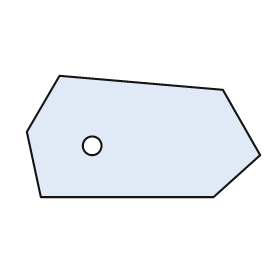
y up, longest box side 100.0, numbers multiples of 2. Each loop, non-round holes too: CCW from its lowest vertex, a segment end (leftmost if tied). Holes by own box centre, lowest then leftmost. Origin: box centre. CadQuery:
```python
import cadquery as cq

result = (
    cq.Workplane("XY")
    .moveTo(-44.0, -26.0)
    .lineTo(30.0, -26.0)
    .lineTo(50.0, -8.0)
    .lineTo(34.0, 20.0)
    .lineTo(-36.0, 26.0)
    .lineTo(-50.0, 2.0)
    .close()
    .moveTo(-22.0, -4.0)
    .circle(4.0)
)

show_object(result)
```